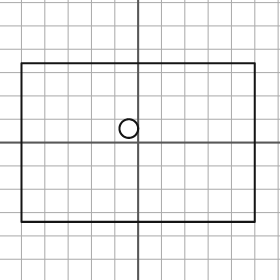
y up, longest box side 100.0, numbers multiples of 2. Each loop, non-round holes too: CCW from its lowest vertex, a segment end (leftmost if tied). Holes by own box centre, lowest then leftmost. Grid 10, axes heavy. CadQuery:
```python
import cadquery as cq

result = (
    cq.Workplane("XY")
    .moveTo(-50.0, -34.0)
    .lineTo(50.0, -34.0)
    .lineTo(50.0, 34.0)
    .lineTo(-50.0, 34.0)
    .close()
    .moveTo(-4.0, 6.0)
    .circle(4.0)
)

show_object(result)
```